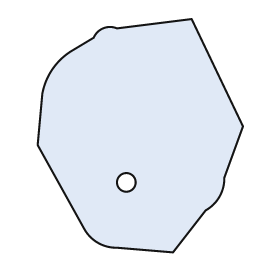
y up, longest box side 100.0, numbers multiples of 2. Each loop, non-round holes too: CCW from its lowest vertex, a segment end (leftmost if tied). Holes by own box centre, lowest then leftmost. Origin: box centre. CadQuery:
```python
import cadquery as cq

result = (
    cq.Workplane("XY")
    .moveTo(14.0, -50.0)
    .lineTo(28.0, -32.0)
    .threePointArc((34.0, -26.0), (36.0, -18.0))
    .lineTo(44.0, 4.0)
    .lineTo(22.0, 50.0)
    .lineTo(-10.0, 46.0)
    .threePointArc((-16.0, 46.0), (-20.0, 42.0))
    .lineTo(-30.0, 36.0)
    .threePointArc((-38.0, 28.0), (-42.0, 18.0))
    .lineTo(-44.0, -4.0)
    .lineTo(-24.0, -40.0)
    .threePointArc((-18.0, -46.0), (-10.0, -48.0))
    .close()
    .moveTo(-6.0, -20.0)
    .circle(4.0)
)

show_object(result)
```